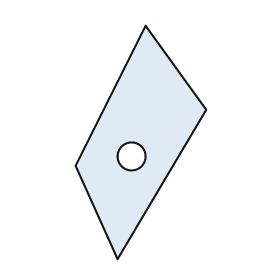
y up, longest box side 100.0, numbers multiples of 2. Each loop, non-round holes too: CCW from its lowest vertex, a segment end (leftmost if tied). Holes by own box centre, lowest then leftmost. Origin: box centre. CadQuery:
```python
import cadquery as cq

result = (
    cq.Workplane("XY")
    .moveTo(-10.0, -50.0)
    .lineTo(28.0, 14.0)
    .lineTo(2.0, 50.0)
    .lineTo(-28.0, -10.0)
    .close()
    .moveTo(-4.0, -6.0)
    .circle(6.0)
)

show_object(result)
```